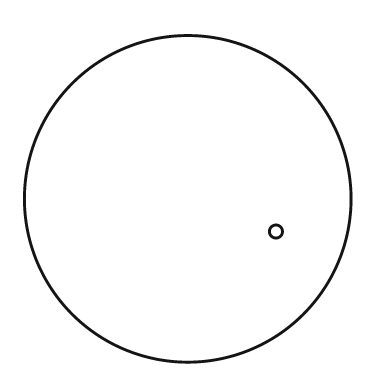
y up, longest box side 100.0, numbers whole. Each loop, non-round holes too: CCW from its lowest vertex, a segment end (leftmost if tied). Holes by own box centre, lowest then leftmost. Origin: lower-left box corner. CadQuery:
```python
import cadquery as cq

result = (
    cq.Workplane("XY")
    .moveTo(50.0, 50.0)
    .circle(50.0)
    .moveTo(77.0, 40.0)
    .circle(2.0)
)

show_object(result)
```